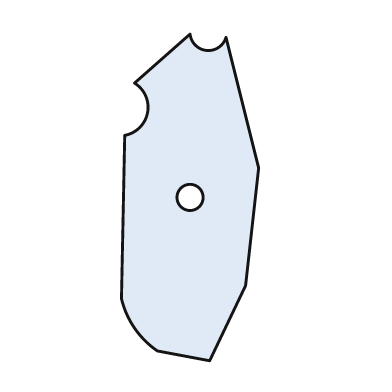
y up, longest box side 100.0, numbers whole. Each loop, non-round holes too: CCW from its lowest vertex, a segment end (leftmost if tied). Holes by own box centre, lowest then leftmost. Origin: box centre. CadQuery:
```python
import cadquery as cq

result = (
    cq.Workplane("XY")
    .moveTo(6.0, -50.0)
    .lineTo(17.0, -27.0)
    .lineTo(21.0, 9.0)
    .lineTo(11.0, 49.0)
    .threePointArc((5.0, 45.0), (0.0, 50.0))
    .lineTo(-17.0, 35.0)
    .threePointArc((-13.0, 26.0), (-20.0, 19.0))
    .lineTo(-21.0, -31.0)
    .threePointArc((-17.0, -40.0), (-10.0, -47.0))
    .close()
    .moveTo(0.0, 0.0)
    .circle(4.0)
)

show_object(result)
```